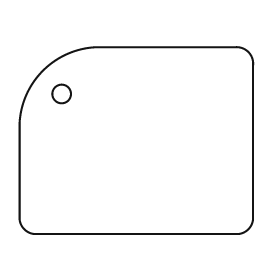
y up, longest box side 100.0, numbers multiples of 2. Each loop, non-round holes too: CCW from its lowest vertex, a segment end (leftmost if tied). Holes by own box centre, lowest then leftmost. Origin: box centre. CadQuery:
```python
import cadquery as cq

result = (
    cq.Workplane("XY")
    .moveTo(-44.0, -40.0)
    .lineTo(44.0, -40.0)
    .threePointArc((48.0, -38.0), (50.0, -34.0))
    .lineTo(50.0, 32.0)
    .threePointArc((48.0, 38.0), (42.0, 40.0))
    .lineTo(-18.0, 40.0)
    .threePointArc((-40.0, 30.0), (-50.0, 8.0))
    .lineTo(-50.0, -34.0)
    .threePointArc((-48.0, -38.0), (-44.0, -40.0))
    .close()
    .moveTo(-32.0, 20.0)
    .circle(4.0)
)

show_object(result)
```